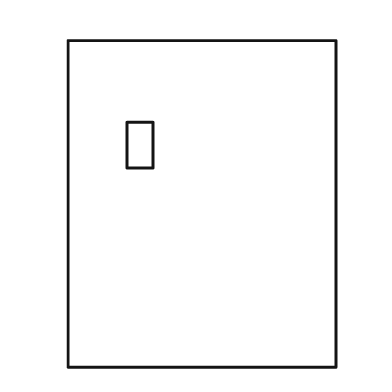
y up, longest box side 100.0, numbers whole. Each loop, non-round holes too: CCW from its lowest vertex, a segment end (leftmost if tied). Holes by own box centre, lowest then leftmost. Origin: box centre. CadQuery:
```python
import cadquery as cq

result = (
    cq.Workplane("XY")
    .moveTo(-41.0, -50.0)
    .lineTo(41.0, -50.0)
    .lineTo(41.0, 50.0)
    .lineTo(-41.0, 50.0)
    .close()
    .moveTo(-23.0, 11.0)
    .lineTo(-15.0, 11.0)
    .lineTo(-15.0, 25.0)
    .lineTo(-23.0, 25.0)
    .close()
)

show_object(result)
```